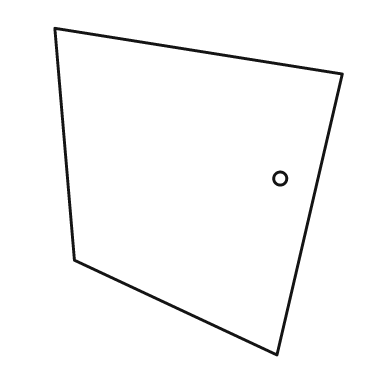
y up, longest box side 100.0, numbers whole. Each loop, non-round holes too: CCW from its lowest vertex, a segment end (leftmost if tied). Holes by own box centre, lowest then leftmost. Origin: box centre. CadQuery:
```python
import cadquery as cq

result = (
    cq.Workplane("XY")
    .moveTo(24.0, -50.0)
    .lineTo(44.0, 36.0)
    .lineTo(-44.0, 50.0)
    .lineTo(-38.0, -21.0)
    .close()
    .moveTo(25.0, 4.0)
    .circle(2.0)
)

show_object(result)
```